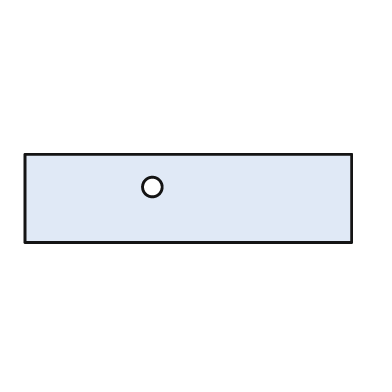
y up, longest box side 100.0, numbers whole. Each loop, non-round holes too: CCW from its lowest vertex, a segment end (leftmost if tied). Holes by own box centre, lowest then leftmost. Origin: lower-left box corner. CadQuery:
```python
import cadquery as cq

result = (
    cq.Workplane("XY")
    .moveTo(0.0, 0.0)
    .lineTo(100.0, 0.0)
    .lineTo(100.0, 27.0)
    .lineTo(0.0, 27.0)
    .close()
    .moveTo(39.0, 17.0)
    .circle(3.0)
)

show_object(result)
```